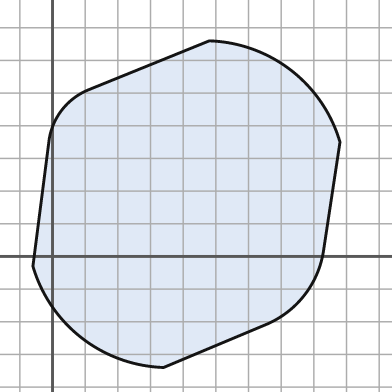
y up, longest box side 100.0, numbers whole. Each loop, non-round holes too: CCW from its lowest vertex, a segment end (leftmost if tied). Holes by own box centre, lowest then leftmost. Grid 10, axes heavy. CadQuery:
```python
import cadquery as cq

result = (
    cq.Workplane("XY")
    .moveTo(34.0, -34.0)
    .lineTo(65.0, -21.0)
    .threePointArc((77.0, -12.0), (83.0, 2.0))
    .lineTo(88.0, 35.0)
    .threePointArc((73.0, 57.0), (48.0, 66.0))
    .lineTo(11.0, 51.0)
    .threePointArc((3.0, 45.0), (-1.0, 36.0))
    .lineTo(-6.0, -3.0)
    .threePointArc((9.0, -25.0), (34.0, -34.0))
    .close()
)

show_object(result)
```